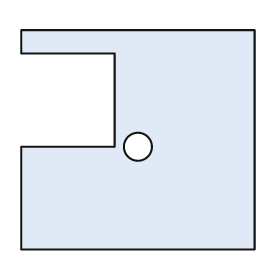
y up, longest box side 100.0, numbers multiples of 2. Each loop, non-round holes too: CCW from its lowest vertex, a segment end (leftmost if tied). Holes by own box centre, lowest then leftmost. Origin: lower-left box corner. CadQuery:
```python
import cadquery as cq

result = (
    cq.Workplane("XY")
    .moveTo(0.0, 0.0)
    .lineTo(100.0, 0.0)
    .lineTo(100.0, 94.0)
    .lineTo(0.0, 94.0)
    .lineTo(0.0, 84.0)
    .lineTo(40.0, 84.0)
    .lineTo(40.0, 44.0)
    .lineTo(0.0, 44.0)
    .close()
    .moveTo(50.0, 44.0)
    .circle(6.0)
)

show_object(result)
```